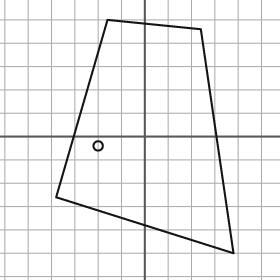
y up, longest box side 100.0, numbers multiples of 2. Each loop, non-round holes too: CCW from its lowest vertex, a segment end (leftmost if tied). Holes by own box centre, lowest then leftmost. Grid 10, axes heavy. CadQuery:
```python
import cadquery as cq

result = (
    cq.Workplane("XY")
    .moveTo(38.0, -50.0)
    .lineTo(24.0, 46.0)
    .lineTo(-16.0, 50.0)
    .lineTo(-38.0, -26.0)
    .close()
    .moveTo(-20.0, -4.0)
    .circle(2.0)
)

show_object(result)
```